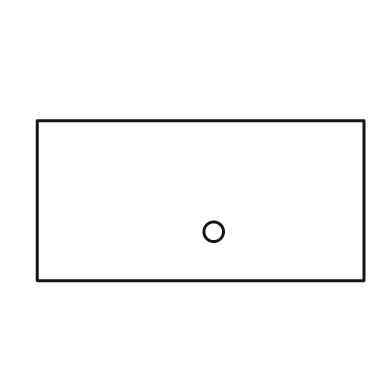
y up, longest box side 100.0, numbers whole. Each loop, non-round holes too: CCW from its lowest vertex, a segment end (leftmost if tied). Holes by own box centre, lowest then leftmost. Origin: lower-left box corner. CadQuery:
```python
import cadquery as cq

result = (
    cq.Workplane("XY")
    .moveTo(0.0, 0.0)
    .lineTo(100.0, 0.0)
    .lineTo(100.0, 49.0)
    .lineTo(0.0, 49.0)
    .close()
    .moveTo(54.0, 15.0)
    .circle(3.0)
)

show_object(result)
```